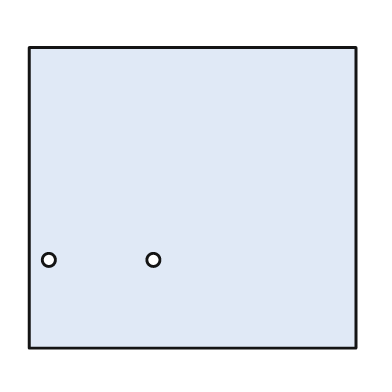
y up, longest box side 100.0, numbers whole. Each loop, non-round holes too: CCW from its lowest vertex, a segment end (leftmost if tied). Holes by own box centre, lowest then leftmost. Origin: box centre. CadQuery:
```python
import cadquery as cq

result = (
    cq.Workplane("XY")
    .moveTo(-50.0, -46.0)
    .lineTo(50.0, -46.0)
    .lineTo(50.0, 46.0)
    .lineTo(-50.0, 46.0)
    .close()
    .moveTo(-44.0, -19.0)
    .circle(2.0)
    .moveTo(-12.0, -19.0)
    .circle(2.0)
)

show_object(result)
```